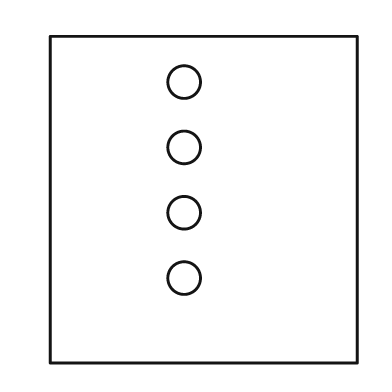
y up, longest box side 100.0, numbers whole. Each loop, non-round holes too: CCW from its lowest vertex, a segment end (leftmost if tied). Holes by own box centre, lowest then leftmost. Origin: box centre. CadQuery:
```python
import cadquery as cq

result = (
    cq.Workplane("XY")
    .moveTo(-47.0, -50.0)
    .lineTo(47.0, -50.0)
    .lineTo(47.0, 50.0)
    .lineTo(-47.0, 50.0)
    .close()
    .moveTo(-6.0, -24.0)
    .circle(5.0)
    .moveTo(-6.0, -4.0)
    .circle(5.0)
    .moveTo(-6.0, 16.0)
    .circle(5.0)
    .moveTo(-6.0, 36.0)
    .circle(5.0)
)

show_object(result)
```